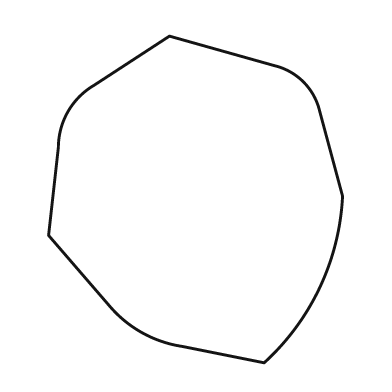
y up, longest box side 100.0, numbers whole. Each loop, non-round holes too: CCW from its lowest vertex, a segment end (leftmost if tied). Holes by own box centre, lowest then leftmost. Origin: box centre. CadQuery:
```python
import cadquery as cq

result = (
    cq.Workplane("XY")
    .moveTo(21.0, -50.0)
    .threePointArc((38.0, -27.0), (45.0, 1.0))
    .lineTo(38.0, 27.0)
    .threePointArc((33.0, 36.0), (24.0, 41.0))
    .lineTo(-8.0, 50.0)
    .lineTo(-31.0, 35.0)
    .threePointArc((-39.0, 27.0), (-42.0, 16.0))
    .lineTo(-45.0, -11.0)
    .lineTo(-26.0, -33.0)
    .threePointArc((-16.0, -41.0), (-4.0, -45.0))
    .close()
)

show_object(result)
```